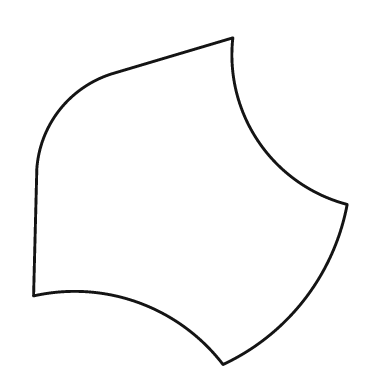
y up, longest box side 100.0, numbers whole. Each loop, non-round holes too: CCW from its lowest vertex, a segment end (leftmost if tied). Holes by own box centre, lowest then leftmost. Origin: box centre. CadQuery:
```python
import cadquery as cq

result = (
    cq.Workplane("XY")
    .moveTo(10.0, -50.0)
    .threePointArc((35.0, -30.0), (48.0, -1.0))
    .threePointArc((21.0, 18.0), (13.0, 50.0))
    .lineTo(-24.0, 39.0)
    .threePointArc((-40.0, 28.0), (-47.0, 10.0))
    .lineTo(-48.0, -29.0)
    .threePointArc((-16.0, -31.0), (10.0, -50.0))
    .close()
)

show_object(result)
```